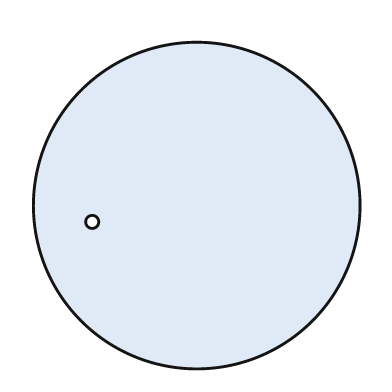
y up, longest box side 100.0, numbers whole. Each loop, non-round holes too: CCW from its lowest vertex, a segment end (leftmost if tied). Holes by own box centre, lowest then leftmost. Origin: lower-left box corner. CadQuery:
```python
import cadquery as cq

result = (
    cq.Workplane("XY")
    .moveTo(50.0, 50.0)
    .circle(50.0)
    .moveTo(18.0, 45.0)
    .circle(2.0)
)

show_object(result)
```